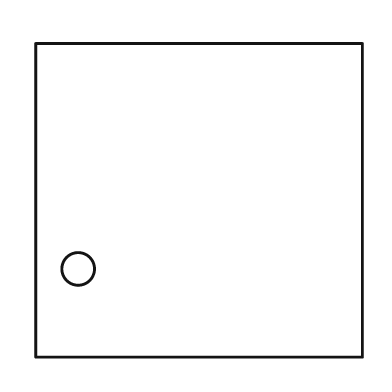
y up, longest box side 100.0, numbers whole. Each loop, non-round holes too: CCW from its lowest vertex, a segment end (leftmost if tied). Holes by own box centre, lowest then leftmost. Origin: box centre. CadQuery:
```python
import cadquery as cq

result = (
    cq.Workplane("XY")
    .moveTo(-50.0, -48.0)
    .lineTo(50.0, -48.0)
    .lineTo(50.0, 48.0)
    .lineTo(-50.0, 48.0)
    .close()
    .moveTo(-37.0, -21.0)
    .circle(5.0)
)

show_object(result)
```